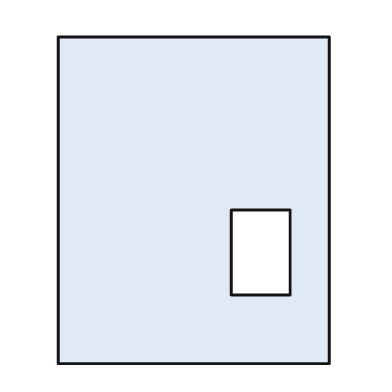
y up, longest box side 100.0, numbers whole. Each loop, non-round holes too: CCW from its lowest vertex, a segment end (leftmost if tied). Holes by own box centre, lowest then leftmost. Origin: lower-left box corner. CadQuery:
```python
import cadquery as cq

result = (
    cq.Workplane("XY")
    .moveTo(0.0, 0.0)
    .lineTo(83.0, 0.0)
    .lineTo(83.0, 100.0)
    .lineTo(0.0, 100.0)
    .close()
    .moveTo(53.0, 21.0)
    .lineTo(71.0, 21.0)
    .lineTo(71.0, 47.0)
    .lineTo(53.0, 47.0)
    .close()
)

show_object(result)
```